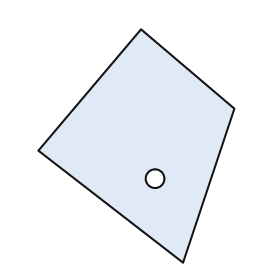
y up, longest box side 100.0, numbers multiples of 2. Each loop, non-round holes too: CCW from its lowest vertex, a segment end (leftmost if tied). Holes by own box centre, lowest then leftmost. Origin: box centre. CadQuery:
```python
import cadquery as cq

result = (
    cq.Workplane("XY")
    .moveTo(20.0, -50.0)
    .lineTo(42.0, 16.0)
    .lineTo(2.0, 50.0)
    .lineTo(-42.0, -2.0)
    .close()
    .moveTo(8.0, -14.0)
    .circle(4.0)
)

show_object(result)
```